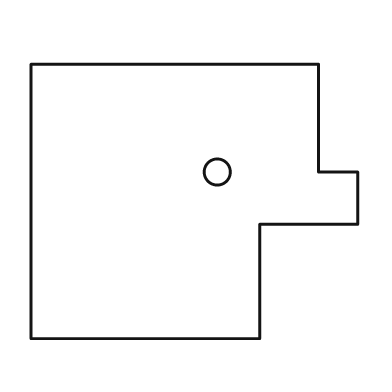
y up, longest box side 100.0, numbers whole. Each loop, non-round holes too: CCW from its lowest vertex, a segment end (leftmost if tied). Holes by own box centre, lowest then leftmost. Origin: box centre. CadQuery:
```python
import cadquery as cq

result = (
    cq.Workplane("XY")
    .moveTo(-50.0, -42.0)
    .lineTo(20.0, -42.0)
    .lineTo(20.0, -7.0)
    .lineTo(50.0, -7.0)
    .lineTo(50.0, 9.0)
    .lineTo(38.0, 9.0)
    .lineTo(38.0, 42.0)
    .lineTo(-50.0, 42.0)
    .close()
    .moveTo(7.0, 9.0)
    .circle(4.0)
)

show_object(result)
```